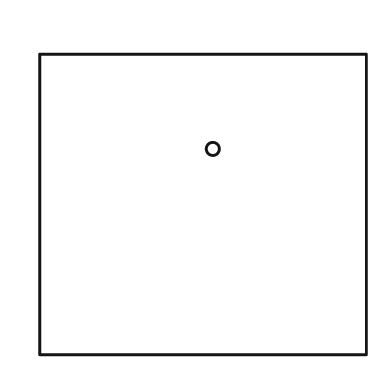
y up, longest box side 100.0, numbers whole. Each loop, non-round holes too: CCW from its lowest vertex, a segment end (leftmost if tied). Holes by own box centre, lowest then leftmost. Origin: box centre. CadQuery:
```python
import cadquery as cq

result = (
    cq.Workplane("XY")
    .moveTo(-50.0, -46.0)
    .lineTo(50.0, -46.0)
    .lineTo(50.0, 46.0)
    .lineTo(-50.0, 46.0)
    .close()
    .moveTo(3.0, 17.0)
    .circle(2.0)
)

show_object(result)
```